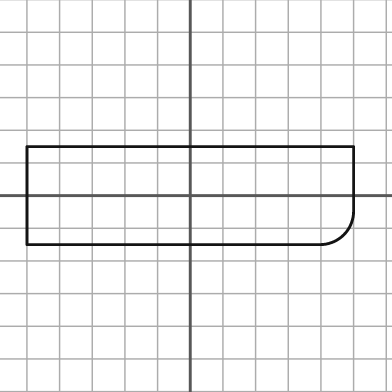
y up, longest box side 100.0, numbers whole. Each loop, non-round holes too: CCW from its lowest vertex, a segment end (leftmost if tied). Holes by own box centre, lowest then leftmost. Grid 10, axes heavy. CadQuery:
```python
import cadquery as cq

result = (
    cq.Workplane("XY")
    .moveTo(-50.0, -15.0)
    .lineTo(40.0, -15.0)
    .threePointArc((47.0, -12.0), (50.0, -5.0))
    .lineTo(50.0, 15.0)
    .lineTo(-50.0, 15.0)
    .close()
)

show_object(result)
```